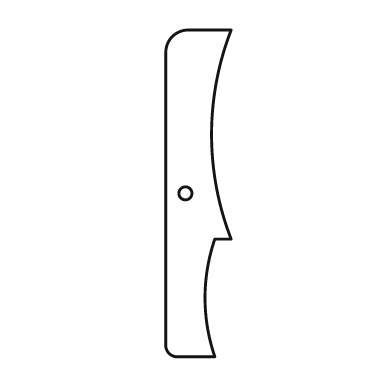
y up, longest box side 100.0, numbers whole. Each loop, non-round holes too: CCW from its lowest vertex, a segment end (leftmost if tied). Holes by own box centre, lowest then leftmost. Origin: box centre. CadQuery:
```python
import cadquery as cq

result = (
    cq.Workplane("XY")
    .moveTo(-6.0, -50.0)
    .lineTo(5.0, -50.0)
    .threePointArc((2.0, -32.0), (5.0, -14.0))
    .lineTo(10.0, -14.0)
    .threePointArc((4.0, 18.0), (10.0, 50.0))
    .lineTo(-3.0, 50.0)
    .threePointArc((-8.0, 48.0), (-10.0, 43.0))
    .lineTo(-10.0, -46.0)
    .threePointArc((-9.0, -49.0), (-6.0, -50.0))
    .close()
    .moveTo(-4.0, 0.0)
    .circle(2.0)
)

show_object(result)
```